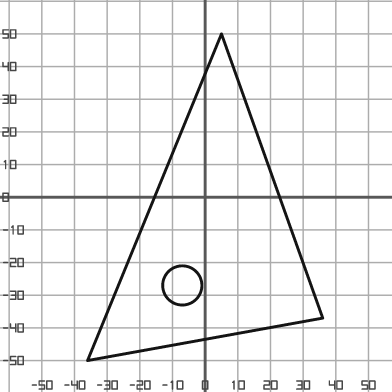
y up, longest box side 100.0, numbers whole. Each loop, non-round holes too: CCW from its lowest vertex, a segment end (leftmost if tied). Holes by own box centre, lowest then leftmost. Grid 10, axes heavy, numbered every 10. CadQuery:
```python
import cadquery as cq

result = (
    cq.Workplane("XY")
    .moveTo(-36.0, -50.0)
    .lineTo(36.0, -37.0)
    .lineTo(5.0, 50.0)
    .close()
    .moveTo(-7.0, -27.0)
    .circle(6.0)
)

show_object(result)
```